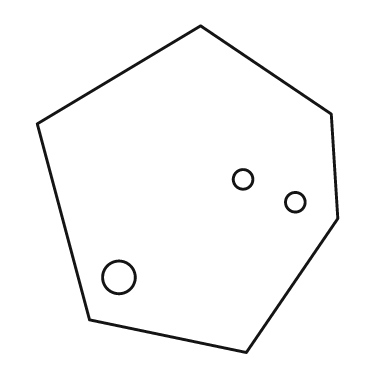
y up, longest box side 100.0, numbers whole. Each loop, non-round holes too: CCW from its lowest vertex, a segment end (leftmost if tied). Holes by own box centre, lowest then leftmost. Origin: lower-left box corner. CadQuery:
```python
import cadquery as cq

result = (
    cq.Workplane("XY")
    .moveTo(64.0, 0.0)
    .lineTo(92.0, 41.0)
    .lineTo(90.0, 73.0)
    .lineTo(50.0, 100.0)
    .lineTo(0.0, 70.0)
    .lineTo(16.0, 10.0)
    .close()
    .moveTo(25.0, 23.0)
    .circle(5.0)
    .moveTo(79.0, 46.0)
    .circle(3.0)
    .moveTo(63.0, 53.0)
    .circle(3.0)
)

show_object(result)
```